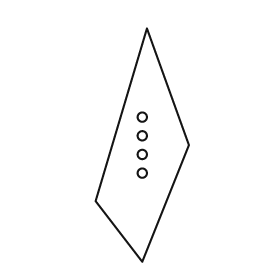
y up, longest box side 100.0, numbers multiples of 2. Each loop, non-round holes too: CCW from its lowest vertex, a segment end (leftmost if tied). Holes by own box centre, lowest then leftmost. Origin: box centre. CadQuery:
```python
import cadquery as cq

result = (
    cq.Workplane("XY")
    .moveTo(0.0, -50.0)
    .lineTo(20.0, 0.0)
    .lineTo(2.0, 50.0)
    .lineTo(-20.0, -24.0)
    .close()
    .moveTo(0.0, -12.0)
    .circle(2.0)
    .moveTo(0.0, -4.0)
    .circle(2.0)
    .moveTo(0.0, 4.0)
    .circle(2.0)
    .moveTo(0.0, 12.0)
    .circle(2.0)
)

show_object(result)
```